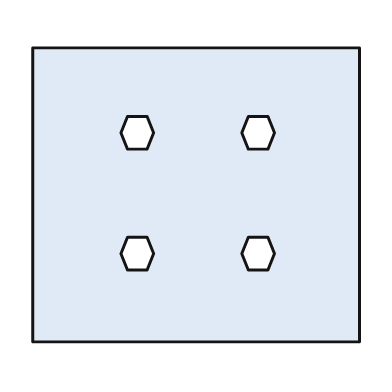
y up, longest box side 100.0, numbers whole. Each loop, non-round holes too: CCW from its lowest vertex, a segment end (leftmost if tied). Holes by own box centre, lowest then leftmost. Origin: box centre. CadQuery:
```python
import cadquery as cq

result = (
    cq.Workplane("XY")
    .moveTo(-50.0, -45.0)
    .lineTo(50.0, -45.0)
    .lineTo(50.0, 45.0)
    .lineTo(-50.0, 45.0)
    .close()
    .moveTo(-21.0, -23.0)
    .lineTo(-15.0, -23.0)
    .lineTo(-13.0, -18.0)
    .lineTo(-15.0, -13.0)
    .lineTo(-21.0, -13.0)
    .lineTo(-23.0, -18.0)
    .close()
    .moveTo(16.0, -23.0)
    .lineTo(22.0, -23.0)
    .lineTo(24.0, -18.0)
    .lineTo(22.0, -13.0)
    .lineTo(16.0, -13.0)
    .lineTo(14.0, -18.0)
    .close()
    .moveTo(-21.0, 14.0)
    .lineTo(-15.0, 14.0)
    .lineTo(-13.0, 19.0)
    .lineTo(-15.0, 24.0)
    .lineTo(-21.0, 24.0)
    .lineTo(-23.0, 19.0)
    .close()
    .moveTo(16.0, 14.0)
    .lineTo(22.0, 14.0)
    .lineTo(24.0, 19.0)
    .lineTo(22.0, 24.0)
    .lineTo(16.0, 24.0)
    .lineTo(14.0, 19.0)
    .close()
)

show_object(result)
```